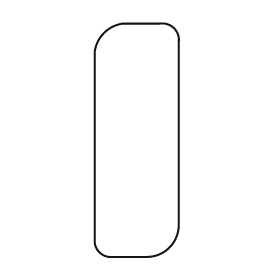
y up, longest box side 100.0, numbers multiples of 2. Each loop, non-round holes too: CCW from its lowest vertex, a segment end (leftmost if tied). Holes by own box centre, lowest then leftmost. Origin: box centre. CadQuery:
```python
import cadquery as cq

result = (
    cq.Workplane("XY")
    .moveTo(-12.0, -50.0)
    .lineTo(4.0, -50.0)
    .threePointArc((14.0, -46.0), (18.0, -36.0))
    .lineTo(18.0, 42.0)
    .threePointArc((16.0, 48.0), (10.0, 50.0))
    .lineTo(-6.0, 50.0)
    .threePointArc((-14.0, 46.0), (-18.0, 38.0))
    .lineTo(-18.0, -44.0)
    .threePointArc((-16.0, -48.0), (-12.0, -50.0))
    .close()
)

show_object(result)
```